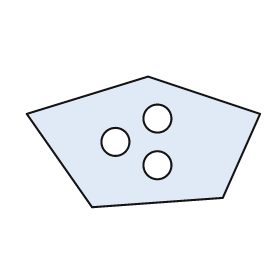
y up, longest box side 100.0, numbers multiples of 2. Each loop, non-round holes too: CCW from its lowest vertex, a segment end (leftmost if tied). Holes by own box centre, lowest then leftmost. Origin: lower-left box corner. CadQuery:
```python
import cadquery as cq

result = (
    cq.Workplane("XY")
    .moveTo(28.0, 0.0)
    .lineTo(84.0, 4.0)
    .lineTo(100.0, 40.0)
    .lineTo(52.0, 56.0)
    .lineTo(0.0, 40.0)
    .close()
    .moveTo(56.0, 18.0)
    .circle(6.0)
    .moveTo(38.0, 28.0)
    .circle(6.0)
    .moveTo(56.0, 38.0)
    .circle(6.0)
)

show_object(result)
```